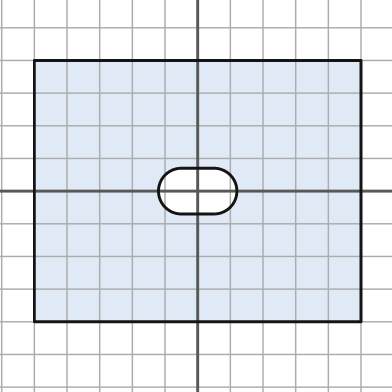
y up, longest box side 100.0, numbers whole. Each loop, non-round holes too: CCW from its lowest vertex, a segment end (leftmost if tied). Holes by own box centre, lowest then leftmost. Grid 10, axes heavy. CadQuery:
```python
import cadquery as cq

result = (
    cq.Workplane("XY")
    .moveTo(-50.0, -40.0)
    .lineTo(50.0, -40.0)
    .lineTo(50.0, 40.0)
    .lineTo(-50.0, 40.0)
    .close()
    .moveTo(-5.0, -7.0)
    .lineTo(5.0, -7.0)
    .threePointArc((12.0, 0.0), (5.0, 7.0))
    .lineTo(-5.0, 7.0)
    .threePointArc((-12.0, 0.0), (-5.0, -7.0))
    .close()
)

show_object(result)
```